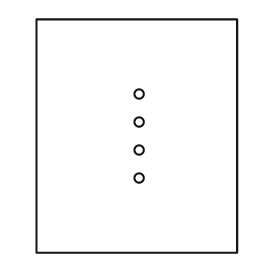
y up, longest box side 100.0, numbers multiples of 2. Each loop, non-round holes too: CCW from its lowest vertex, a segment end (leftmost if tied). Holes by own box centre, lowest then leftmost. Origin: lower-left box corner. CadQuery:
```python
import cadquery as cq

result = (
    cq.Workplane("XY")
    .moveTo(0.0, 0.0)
    .lineTo(86.0, 0.0)
    .lineTo(86.0, 100.0)
    .lineTo(0.0, 100.0)
    .close()
    .moveTo(44.0, 32.0)
    .circle(2.0)
    .moveTo(44.0, 44.0)
    .circle(2.0)
    .moveTo(44.0, 56.0)
    .circle(2.0)
    .moveTo(44.0, 68.0)
    .circle(2.0)
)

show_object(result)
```